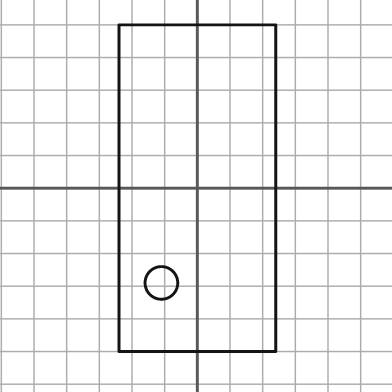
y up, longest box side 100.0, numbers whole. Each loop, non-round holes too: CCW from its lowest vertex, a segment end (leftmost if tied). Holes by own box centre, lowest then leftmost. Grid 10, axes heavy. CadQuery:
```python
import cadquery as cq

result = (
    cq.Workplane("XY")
    .moveTo(-24.0, -50.0)
    .lineTo(24.0, -50.0)
    .lineTo(24.0, 50.0)
    .lineTo(-24.0, 50.0)
    .close()
    .moveTo(-11.0, -29.0)
    .circle(5.0)
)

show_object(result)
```